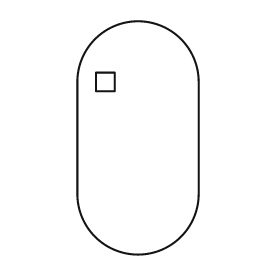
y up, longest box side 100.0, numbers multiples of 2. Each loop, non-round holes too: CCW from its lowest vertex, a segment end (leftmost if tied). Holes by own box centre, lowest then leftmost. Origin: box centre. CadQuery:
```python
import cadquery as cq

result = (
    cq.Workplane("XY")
    .moveTo(-26.0, -24.0)
    .threePointArc((0.0, -50.0), (26.0, -24.0))
    .lineTo(26.0, 24.0)
    .threePointArc((0.0, 50.0), (-26.0, 24.0))
    .close()
    .moveTo(-18.0, 20.0)
    .lineTo(-10.0, 20.0)
    .lineTo(-10.0, 28.0)
    .lineTo(-18.0, 28.0)
    .close()
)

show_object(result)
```